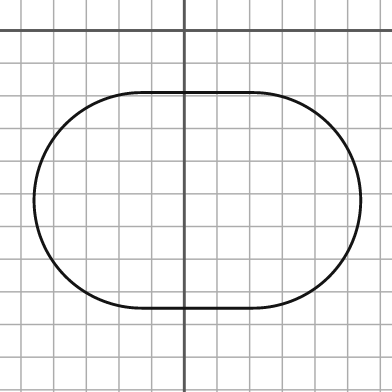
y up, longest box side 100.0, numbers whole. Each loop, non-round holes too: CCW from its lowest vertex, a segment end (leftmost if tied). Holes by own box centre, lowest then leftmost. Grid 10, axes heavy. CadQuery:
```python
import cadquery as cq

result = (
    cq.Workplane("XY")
    .moveTo(-13.0, -85.0)
    .lineTo(21.0, -85.0)
    .threePointArc((54.0, -52.0), (21.0, -19.0))
    .lineTo(-13.0, -19.0)
    .threePointArc((-46.0, -52.0), (-13.0, -85.0))
    .close()
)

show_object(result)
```